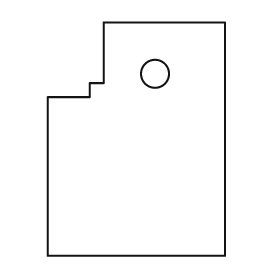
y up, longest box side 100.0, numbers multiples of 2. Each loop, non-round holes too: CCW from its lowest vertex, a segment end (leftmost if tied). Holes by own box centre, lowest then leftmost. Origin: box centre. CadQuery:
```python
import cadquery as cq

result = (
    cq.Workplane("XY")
    .moveTo(-38.0, -50.0)
    .lineTo(38.0, -50.0)
    .lineTo(38.0, 50.0)
    .lineTo(-14.0, 50.0)
    .lineTo(-14.0, 24.0)
    .lineTo(-20.0, 24.0)
    .lineTo(-20.0, 18.0)
    .lineTo(-38.0, 18.0)
    .close()
    .moveTo(8.0, 28.0)
    .circle(6.0)
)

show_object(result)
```